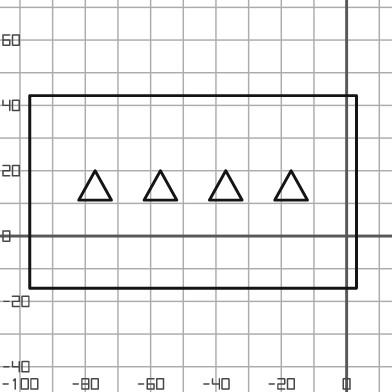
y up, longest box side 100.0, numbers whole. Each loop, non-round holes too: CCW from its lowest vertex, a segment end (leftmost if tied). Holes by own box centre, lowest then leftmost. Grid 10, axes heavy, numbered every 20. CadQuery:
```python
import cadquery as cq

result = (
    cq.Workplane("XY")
    .moveTo(-97.0, -16.0)
    .lineTo(3.0, -16.0)
    .lineTo(3.0, 43.0)
    .lineTo(-97.0, 43.0)
    .close()
    .moveTo(-82.0, 11.0)
    .lineTo(-72.0, 11.0)
    .lineTo(-77.0, 20.0)
    .close()
    .moveTo(-62.0, 11.0)
    .lineTo(-52.0, 11.0)
    .lineTo(-57.0, 20.0)
    .close()
    .moveTo(-42.0, 11.0)
    .lineTo(-32.0, 11.0)
    .lineTo(-37.0, 20.0)
    .close()
    .moveTo(-22.0, 11.0)
    .lineTo(-12.0, 11.0)
    .lineTo(-17.0, 20.0)
    .close()
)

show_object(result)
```